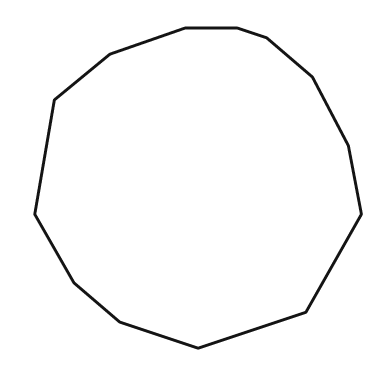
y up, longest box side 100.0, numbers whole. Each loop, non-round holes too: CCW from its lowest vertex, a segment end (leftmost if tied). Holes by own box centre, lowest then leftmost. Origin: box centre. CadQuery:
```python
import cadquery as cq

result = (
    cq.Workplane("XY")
    .moveTo(0.0, -49.0)
    .lineTo(33.0, -38.0)
    .lineTo(50.0, -8.0)
    .lineTo(46.0, 13.0)
    .lineTo(35.0, 34.0)
    .lineTo(21.0, 46.0)
    .lineTo(12.0, 49.0)
    .lineTo(-4.0, 49.0)
    .lineTo(-27.0, 41.0)
    .lineTo(-44.0, 27.0)
    .lineTo(-50.0, -8.0)
    .lineTo(-38.0, -29.0)
    .lineTo(-24.0, -41.0)
    .close()
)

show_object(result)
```